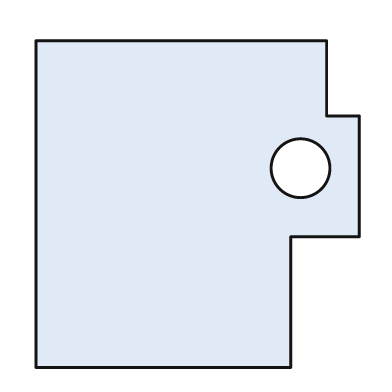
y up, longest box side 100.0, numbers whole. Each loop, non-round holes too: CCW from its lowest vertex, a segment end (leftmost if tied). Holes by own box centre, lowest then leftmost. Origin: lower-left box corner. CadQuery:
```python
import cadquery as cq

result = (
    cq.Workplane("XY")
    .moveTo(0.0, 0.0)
    .lineTo(78.0, 0.0)
    .lineTo(78.0, 40.0)
    .lineTo(99.0, 40.0)
    .lineTo(99.0, 77.0)
    .lineTo(89.0, 77.0)
    .lineTo(89.0, 100.0)
    .lineTo(0.0, 100.0)
    .close()
    .moveTo(81.0, 61.0)
    .circle(9.0)
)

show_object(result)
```